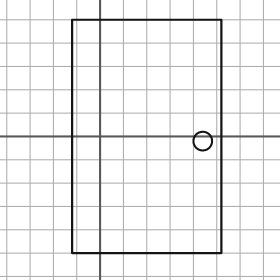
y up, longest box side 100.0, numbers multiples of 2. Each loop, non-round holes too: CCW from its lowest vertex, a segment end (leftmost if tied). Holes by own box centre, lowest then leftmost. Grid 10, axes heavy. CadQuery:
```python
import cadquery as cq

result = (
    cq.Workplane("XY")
    .moveTo(-12.0, -50.0)
    .lineTo(52.0, -50.0)
    .lineTo(52.0, 50.0)
    .lineTo(-12.0, 50.0)
    .close()
    .moveTo(44.0, -2.0)
    .circle(4.0)
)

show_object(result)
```